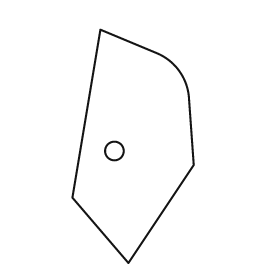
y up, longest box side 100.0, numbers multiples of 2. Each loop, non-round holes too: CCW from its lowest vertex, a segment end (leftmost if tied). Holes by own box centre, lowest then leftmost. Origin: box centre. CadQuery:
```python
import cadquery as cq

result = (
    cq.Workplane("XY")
    .moveTo(-2.0, -50.0)
    .lineTo(26.0, -8.0)
    .lineTo(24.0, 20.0)
    .threePointArc((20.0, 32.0), (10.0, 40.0))
    .lineTo(-14.0, 50.0)
    .lineTo(-26.0, -22.0)
    .close()
    .moveTo(-8.0, -2.0)
    .circle(4.0)
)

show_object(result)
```